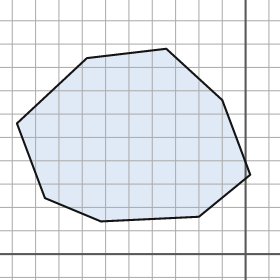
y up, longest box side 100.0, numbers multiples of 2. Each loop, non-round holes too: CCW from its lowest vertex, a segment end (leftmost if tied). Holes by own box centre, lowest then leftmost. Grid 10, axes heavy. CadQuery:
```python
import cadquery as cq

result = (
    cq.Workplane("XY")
    .moveTo(-62.0, 14.0)
    .lineTo(-20.0, 16.0)
    .lineTo(2.0, 34.0)
    .lineTo(-10.0, 66.0)
    .lineTo(-34.0, 88.0)
    .lineTo(-68.0, 84.0)
    .lineTo(-98.0, 56.0)
    .lineTo(-86.0, 24.0)
    .close()
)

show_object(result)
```